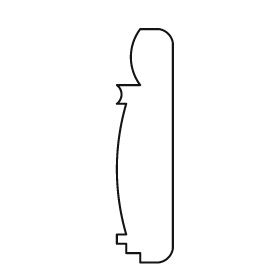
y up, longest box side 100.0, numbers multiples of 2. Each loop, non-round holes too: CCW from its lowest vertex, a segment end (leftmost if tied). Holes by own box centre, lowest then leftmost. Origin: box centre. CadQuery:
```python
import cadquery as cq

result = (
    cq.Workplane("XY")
    .moveTo(-2.0, -50.0)
    .lineTo(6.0, -50.0)
    .threePointArc((10.0, -48.0), (12.0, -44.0))
    .lineTo(12.0, 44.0)
    .threePointArc((10.0, 48.0), (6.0, 50.0))
    .lineTo(-2.0, 50.0)
    .threePointArc((-6.0, 38.0), (-2.0, 26.0))
    .lineTo(-12.0, 26.0)
    .threePointArc((-10.0, 22.0), (-12.0, 18.0))
    .lineTo(-8.0, 18.0)
    .threePointArc((-12.0, -10.0), (-8.0, -38.0))
    .lineTo(-12.0, -38.0)
    .lineTo(-12.0, -42.0)
    .lineTo(-8.0, -42.0)
    .lineTo(-8.0, -46.0)
    .lineTo(-2.0, -46.0)
    .close()
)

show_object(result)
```